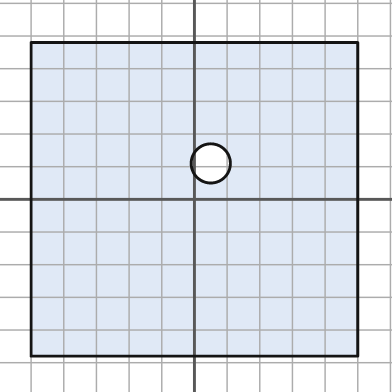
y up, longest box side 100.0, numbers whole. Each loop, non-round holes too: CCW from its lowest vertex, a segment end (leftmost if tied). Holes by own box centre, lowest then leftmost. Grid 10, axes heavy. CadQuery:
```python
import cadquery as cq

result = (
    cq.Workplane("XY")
    .moveTo(-50.0, -48.0)
    .lineTo(50.0, -48.0)
    .lineTo(50.0, 48.0)
    .lineTo(-50.0, 48.0)
    .close()
    .moveTo(5.0, 11.0)
    .circle(6.0)
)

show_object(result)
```